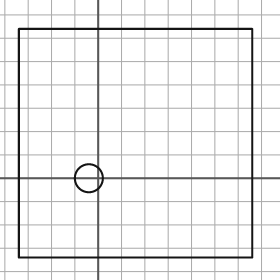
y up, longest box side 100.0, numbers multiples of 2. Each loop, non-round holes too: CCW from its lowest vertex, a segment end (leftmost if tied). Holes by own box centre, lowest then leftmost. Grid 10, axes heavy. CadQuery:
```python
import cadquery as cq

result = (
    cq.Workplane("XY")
    .moveTo(-34.0, -34.0)
    .lineTo(66.0, -34.0)
    .lineTo(66.0, 64.0)
    .lineTo(-34.0, 64.0)
    .close()
    .moveTo(-4.0, 0.0)
    .circle(6.0)
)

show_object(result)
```